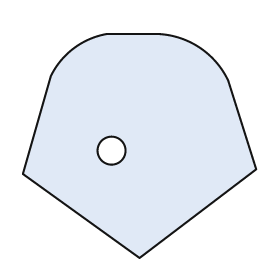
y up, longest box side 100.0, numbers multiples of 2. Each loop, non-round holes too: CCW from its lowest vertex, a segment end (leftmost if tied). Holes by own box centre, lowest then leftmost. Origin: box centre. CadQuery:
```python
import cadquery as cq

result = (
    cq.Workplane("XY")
    .moveTo(0.0, -48.0)
    .lineTo(50.0, -10.0)
    .lineTo(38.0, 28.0)
    .threePointArc((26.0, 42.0), (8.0, 48.0))
    .lineTo(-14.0, 48.0)
    .threePointArc((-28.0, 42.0), (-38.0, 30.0))
    .lineTo(-50.0, -12.0)
    .close()
    .moveTo(-12.0, -2.0)
    .circle(6.0)
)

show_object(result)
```